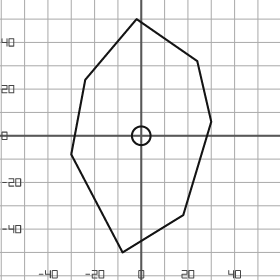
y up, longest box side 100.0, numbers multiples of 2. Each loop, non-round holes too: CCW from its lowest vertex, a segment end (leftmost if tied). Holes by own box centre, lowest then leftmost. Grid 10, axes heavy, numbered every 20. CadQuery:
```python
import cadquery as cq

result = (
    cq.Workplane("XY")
    .moveTo(-8.0, -50.0)
    .lineTo(18.0, -34.0)
    .lineTo(30.0, 6.0)
    .lineTo(24.0, 32.0)
    .lineTo(-2.0, 50.0)
    .lineTo(-24.0, 24.0)
    .lineTo(-30.0, -8.0)
    .close()
    .moveTo(0.0, 0.0)
    .circle(4.0)
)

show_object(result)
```